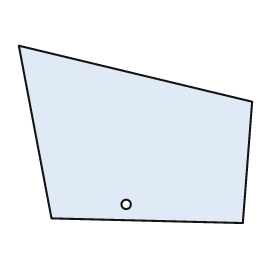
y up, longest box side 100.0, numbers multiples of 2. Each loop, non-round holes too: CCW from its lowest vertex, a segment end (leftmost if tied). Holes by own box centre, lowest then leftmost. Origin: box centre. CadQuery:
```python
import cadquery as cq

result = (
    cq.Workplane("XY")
    .moveTo(46.0, -38.0)
    .lineTo(50.0, 14.0)
    .lineTo(-50.0, 38.0)
    .lineTo(-36.0, -36.0)
    .close()
    .moveTo(-4.0, -30.0)
    .circle(2.0)
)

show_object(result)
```